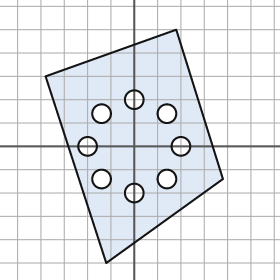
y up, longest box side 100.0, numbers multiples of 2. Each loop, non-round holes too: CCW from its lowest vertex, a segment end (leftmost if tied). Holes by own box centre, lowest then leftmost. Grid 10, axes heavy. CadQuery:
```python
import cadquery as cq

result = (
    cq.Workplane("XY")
    .moveTo(-12.0, -50.0)
    .lineTo(38.0, -14.0)
    .lineTo(18.0, 50.0)
    .lineTo(-38.0, 30.0)
    .close()
    .moveTo(0.0, -20.0)
    .circle(4.0)
    .moveTo(-14.0, -14.0)
    .circle(4.0)
    .moveTo(14.0, -14.0)
    .circle(4.0)
    .moveTo(-20.0, 0.0)
    .circle(4.0)
    .moveTo(20.0, 0.0)
    .circle(4.0)
    .moveTo(-14.0, 14.0)
    .circle(4.0)
    .moveTo(14.0, 14.0)
    .circle(4.0)
    .moveTo(0.0, 20.0)
    .circle(4.0)
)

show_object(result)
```